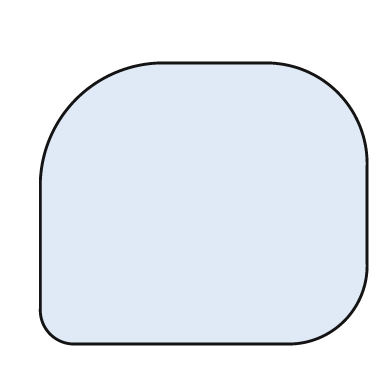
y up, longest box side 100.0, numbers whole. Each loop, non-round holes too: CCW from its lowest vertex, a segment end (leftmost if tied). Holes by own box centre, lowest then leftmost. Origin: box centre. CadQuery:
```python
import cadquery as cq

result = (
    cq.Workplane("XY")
    .moveTo(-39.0, -43.0)
    .lineTo(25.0, -43.0)
    .threePointArc((43.0, -36.0), (50.0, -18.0))
    .lineTo(50.0, 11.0)
    .threePointArc((41.0, 34.0), (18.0, 43.0))
    .lineTo(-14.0, 43.0)
    .threePointArc((-39.0, 32.0), (-50.0, 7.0))
    .lineTo(-50.0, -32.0)
    .threePointArc((-47.0, -40.0), (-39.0, -43.0))
    .close()
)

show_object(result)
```